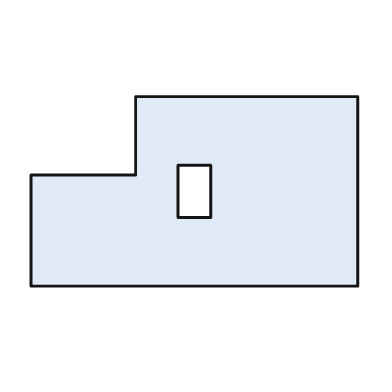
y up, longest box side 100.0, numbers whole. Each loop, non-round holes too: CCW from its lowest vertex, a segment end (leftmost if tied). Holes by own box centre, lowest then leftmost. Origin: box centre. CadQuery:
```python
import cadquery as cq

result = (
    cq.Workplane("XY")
    .moveTo(-50.0, -29.0)
    .lineTo(50.0, -29.0)
    .lineTo(50.0, 29.0)
    .lineTo(-18.0, 29.0)
    .lineTo(-18.0, 5.0)
    .lineTo(-50.0, 5.0)
    .close()
    .moveTo(-5.0, -8.0)
    .lineTo(5.0, -8.0)
    .lineTo(5.0, 8.0)
    .lineTo(-5.0, 8.0)
    .close()
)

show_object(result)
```